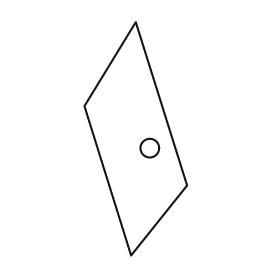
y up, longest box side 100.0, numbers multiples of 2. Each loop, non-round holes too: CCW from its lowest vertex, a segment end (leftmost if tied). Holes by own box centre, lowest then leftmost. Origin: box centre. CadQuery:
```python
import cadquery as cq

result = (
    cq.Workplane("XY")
    .moveTo(-2.0, -50.0)
    .lineTo(22.0, -20.0)
    .lineTo(0.0, 50.0)
    .lineTo(-22.0, 14.0)
    .close()
    .moveTo(6.0, -4.0)
    .circle(4.0)
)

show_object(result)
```